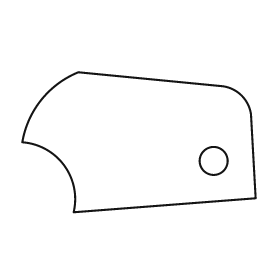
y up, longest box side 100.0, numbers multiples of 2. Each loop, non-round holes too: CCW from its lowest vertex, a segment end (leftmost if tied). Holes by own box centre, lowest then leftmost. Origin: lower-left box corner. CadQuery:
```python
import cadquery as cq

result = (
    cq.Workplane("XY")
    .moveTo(22.0, 0.0)
    .lineTo(100.0, 6.0)
    .lineTo(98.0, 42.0)
    .threePointArc((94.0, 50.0), (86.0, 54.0))
    .lineTo(24.0, 60.0)
    .threePointArc((8.0, 48.0), (0.0, 30.0))
    .threePointArc((18.0, 20.0), (22.0, 0.0))
    .close()
    .moveTo(82.0, 22.0)
    .circle(6.0)
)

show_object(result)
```